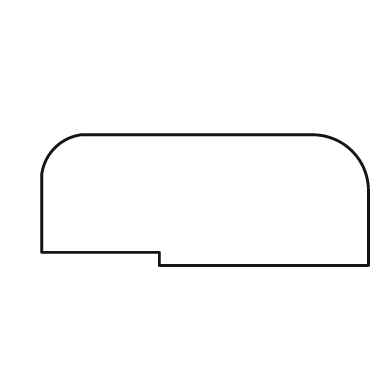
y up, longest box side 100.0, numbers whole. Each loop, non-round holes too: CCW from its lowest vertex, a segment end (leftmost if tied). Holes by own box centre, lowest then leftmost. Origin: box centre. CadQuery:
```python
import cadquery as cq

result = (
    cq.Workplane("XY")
    .moveTo(-14.0, -20.0)
    .lineTo(50.0, -20.0)
    .lineTo(50.0, 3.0)
    .threePointArc((45.0, 15.0), (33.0, 20.0))
    .lineTo(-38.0, 20.0)
    .threePointArc((-46.0, 16.0), (-50.0, 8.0))
    .lineTo(-50.0, -16.0)
    .lineTo(-14.0, -16.0)
    .close()
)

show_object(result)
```